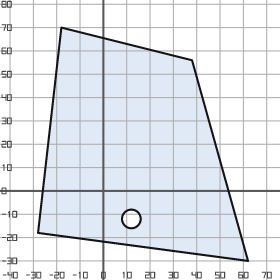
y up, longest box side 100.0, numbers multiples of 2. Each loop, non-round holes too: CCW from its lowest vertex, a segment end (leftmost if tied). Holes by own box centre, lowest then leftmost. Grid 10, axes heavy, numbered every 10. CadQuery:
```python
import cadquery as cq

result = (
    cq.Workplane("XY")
    .moveTo(62.0, -30.0)
    .lineTo(38.0, 56.0)
    .lineTo(-18.0, 70.0)
    .lineTo(-28.0, -18.0)
    .close()
    .moveTo(12.0, -12.0)
    .circle(4.0)
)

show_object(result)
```